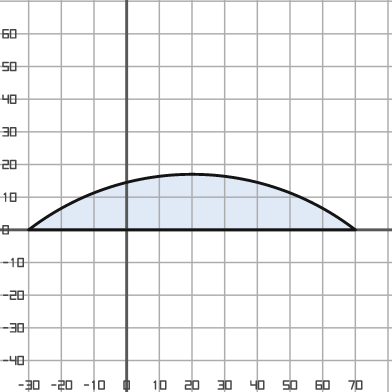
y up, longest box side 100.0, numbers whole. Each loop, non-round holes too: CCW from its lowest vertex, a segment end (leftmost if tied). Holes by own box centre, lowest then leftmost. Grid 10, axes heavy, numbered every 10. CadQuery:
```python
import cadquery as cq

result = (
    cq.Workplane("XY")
    .moveTo(-30.0, 0.0)
    .lineTo(70.0, 0.0)
    .threePointArc((20.0, 17.0), (-30.0, 0.0))
    .close()
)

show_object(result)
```